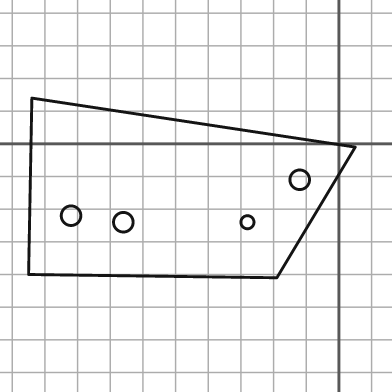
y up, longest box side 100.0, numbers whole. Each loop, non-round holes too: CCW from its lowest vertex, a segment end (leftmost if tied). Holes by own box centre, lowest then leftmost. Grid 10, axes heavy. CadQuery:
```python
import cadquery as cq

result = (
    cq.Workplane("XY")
    .moveTo(-19.0, -41.0)
    .lineTo(5.0, -1.0)
    .lineTo(-94.0, 14.0)
    .lineTo(-95.0, -40.0)
    .close()
    .moveTo(-66.0, -24.0)
    .circle(3.0)
    .moveTo(-28.0, -24.0)
    .circle(2.0)
    .moveTo(-82.0, -22.0)
    .circle(3.0)
    .moveTo(-12.0, -11.0)
    .circle(3.0)
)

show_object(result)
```